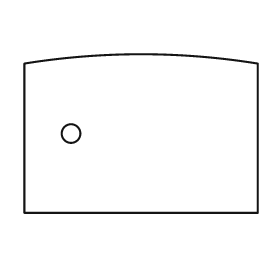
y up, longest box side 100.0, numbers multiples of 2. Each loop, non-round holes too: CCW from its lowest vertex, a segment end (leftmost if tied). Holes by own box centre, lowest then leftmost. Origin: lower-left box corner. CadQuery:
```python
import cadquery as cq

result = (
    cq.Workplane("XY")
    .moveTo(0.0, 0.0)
    .lineTo(100.0, 0.0)
    .lineTo(100.0, 64.0)
    .threePointArc((50.0, 68.0), (0.0, 64.0))
    .close()
    .moveTo(20.0, 34.0)
    .circle(4.0)
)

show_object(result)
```